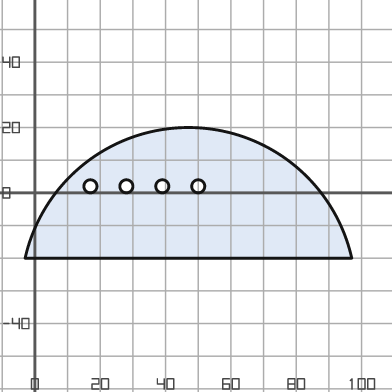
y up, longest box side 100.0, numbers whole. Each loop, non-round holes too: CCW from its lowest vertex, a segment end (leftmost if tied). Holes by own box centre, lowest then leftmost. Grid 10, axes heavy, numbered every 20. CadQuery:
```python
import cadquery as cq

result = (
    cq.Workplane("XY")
    .moveTo(-3.0, -20.0)
    .lineTo(97.0, -20.0)
    .threePointArc((47.0, 20.0), (-3.0, -20.0))
    .close()
    .moveTo(17.0, 2.0)
    .circle(2.0)
    .moveTo(28.0, 2.0)
    .circle(2.0)
    .moveTo(39.0, 2.0)
    .circle(2.0)
    .moveTo(50.0, 2.0)
    .circle(2.0)
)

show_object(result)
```